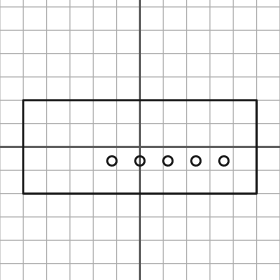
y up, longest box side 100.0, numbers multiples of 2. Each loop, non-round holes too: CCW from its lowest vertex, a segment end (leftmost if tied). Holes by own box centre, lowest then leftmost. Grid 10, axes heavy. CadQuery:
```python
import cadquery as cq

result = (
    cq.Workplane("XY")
    .moveTo(-50.0, -20.0)
    .lineTo(50.0, -20.0)
    .lineTo(50.0, 20.0)
    .lineTo(-50.0, 20.0)
    .close()
    .moveTo(-12.0, -6.0)
    .circle(2.0)
    .moveTo(0.0, -6.0)
    .circle(2.0)
    .moveTo(12.0, -6.0)
    .circle(2.0)
    .moveTo(24.0, -6.0)
    .circle(2.0)
    .moveTo(36.0, -6.0)
    .circle(2.0)
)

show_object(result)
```